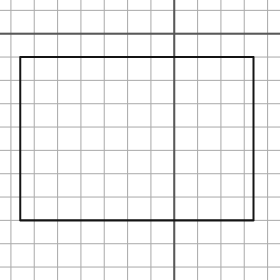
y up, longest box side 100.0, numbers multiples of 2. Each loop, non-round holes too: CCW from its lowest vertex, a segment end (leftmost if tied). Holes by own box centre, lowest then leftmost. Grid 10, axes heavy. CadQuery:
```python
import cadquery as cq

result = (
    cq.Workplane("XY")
    .moveTo(-66.0, -80.0)
    .lineTo(34.0, -80.0)
    .lineTo(34.0, -10.0)
    .lineTo(-66.0, -10.0)
    .close()
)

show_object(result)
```